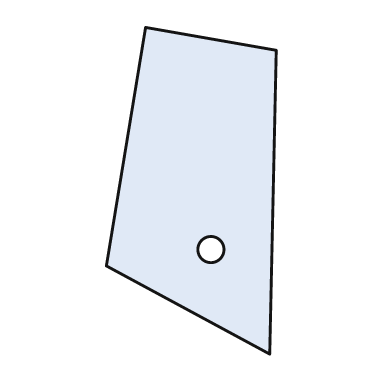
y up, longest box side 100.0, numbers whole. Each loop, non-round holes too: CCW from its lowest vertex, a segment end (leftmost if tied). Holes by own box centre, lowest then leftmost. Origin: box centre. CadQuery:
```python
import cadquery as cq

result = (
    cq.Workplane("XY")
    .moveTo(24.0, -50.0)
    .lineTo(26.0, 43.0)
    .lineTo(-14.0, 50.0)
    .lineTo(-26.0, -23.0)
    .close()
    .moveTo(6.0, -18.0)
    .circle(4.0)
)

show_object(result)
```